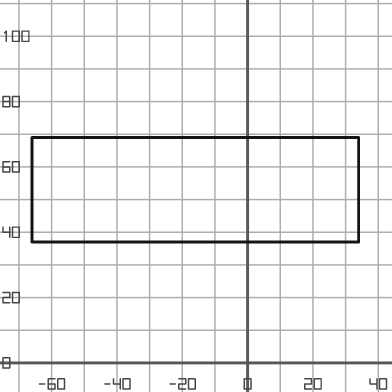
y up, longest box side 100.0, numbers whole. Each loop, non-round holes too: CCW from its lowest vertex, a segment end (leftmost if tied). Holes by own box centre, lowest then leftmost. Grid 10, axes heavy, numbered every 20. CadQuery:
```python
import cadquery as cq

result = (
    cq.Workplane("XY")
    .moveTo(-66.0, 37.0)
    .lineTo(34.0, 37.0)
    .lineTo(34.0, 69.0)
    .lineTo(-66.0, 69.0)
    .close()
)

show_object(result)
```